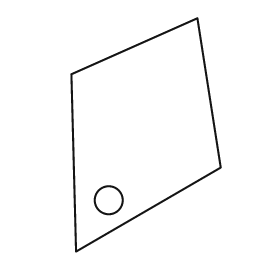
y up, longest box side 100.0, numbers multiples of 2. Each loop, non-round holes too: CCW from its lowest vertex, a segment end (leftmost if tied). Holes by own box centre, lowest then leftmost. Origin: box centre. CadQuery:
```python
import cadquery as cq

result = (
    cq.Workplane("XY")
    .moveTo(-30.0, -50.0)
    .lineTo(32.0, -14.0)
    .lineTo(22.0, 50.0)
    .lineTo(-32.0, 26.0)
    .close()
    .moveTo(-16.0, -28.0)
    .circle(6.0)
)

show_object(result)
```